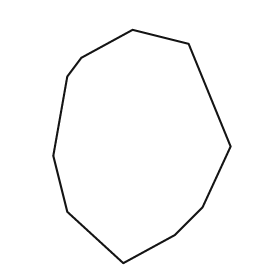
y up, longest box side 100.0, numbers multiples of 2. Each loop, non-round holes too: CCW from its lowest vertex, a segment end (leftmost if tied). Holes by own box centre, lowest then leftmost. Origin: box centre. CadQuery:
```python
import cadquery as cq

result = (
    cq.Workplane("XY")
    .moveTo(-8.0, -50.0)
    .lineTo(14.0, -38.0)
    .lineTo(26.0, -26.0)
    .lineTo(38.0, 0.0)
    .lineTo(20.0, 44.0)
    .lineTo(-4.0, 50.0)
    .lineTo(-26.0, 38.0)
    .lineTo(-32.0, 30.0)
    .lineTo(-38.0, -4.0)
    .lineTo(-32.0, -28.0)
    .close()
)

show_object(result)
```